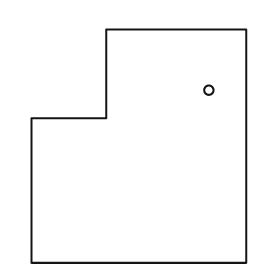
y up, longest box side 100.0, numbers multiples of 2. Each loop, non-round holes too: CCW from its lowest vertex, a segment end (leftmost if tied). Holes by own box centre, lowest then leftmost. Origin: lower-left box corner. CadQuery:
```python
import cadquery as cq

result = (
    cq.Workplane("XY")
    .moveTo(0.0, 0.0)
    .lineTo(92.0, 0.0)
    .lineTo(92.0, 100.0)
    .lineTo(32.0, 100.0)
    .lineTo(32.0, 62.0)
    .lineTo(0.0, 62.0)
    .close()
    .moveTo(76.0, 74.0)
    .circle(2.0)
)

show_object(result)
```